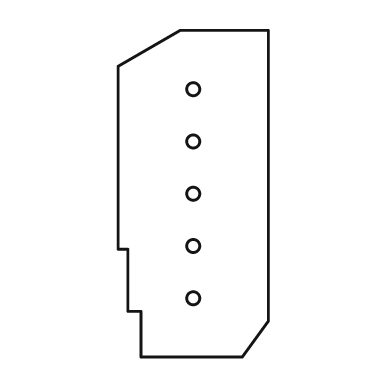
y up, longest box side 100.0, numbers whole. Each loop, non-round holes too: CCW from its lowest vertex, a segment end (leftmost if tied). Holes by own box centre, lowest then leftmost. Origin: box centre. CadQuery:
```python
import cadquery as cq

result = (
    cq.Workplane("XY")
    .moveTo(-16.0, -50.0)
    .lineTo(15.0, -50.0)
    .lineTo(23.0, -39.0)
    .lineTo(23.0, 50.0)
    .lineTo(-4.0, 50.0)
    .lineTo(-23.0, 39.0)
    .lineTo(-23.0, -17.0)
    .lineTo(-20.0, -17.0)
    .lineTo(-20.0, -36.0)
    .lineTo(-16.0, -36.0)
    .close()
    .moveTo(0.0, -32.0)
    .circle(2.0)
    .moveTo(0.0, -16.0)
    .circle(2.0)
    .moveTo(0.0, 0.0)
    .circle(2.0)
    .moveTo(0.0, 16.0)
    .circle(2.0)
    .moveTo(0.0, 32.0)
    .circle(2.0)
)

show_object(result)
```